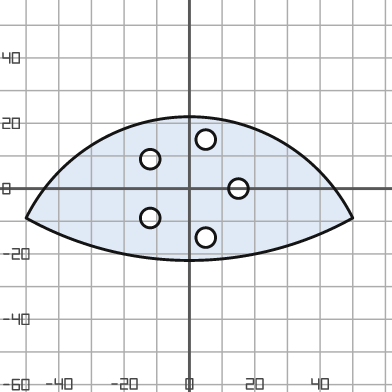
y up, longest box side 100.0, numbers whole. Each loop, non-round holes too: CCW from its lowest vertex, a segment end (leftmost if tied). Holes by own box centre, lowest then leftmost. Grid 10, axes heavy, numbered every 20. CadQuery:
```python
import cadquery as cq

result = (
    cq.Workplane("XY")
    .moveTo(-50.0, -9.0)
    .threePointArc((0.0, -22.0), (50.0, -9.0))
    .threePointArc((0.0, 22.0), (-50.0, -9.0))
    .close()
    .moveTo(5.0, -15.0)
    .circle(3.0)
    .moveTo(-12.0, -9.0)
    .circle(3.0)
    .moveTo(15.0, 0.0)
    .circle(3.0)
    .moveTo(-12.0, 9.0)
    .circle(3.0)
    .moveTo(5.0, 15.0)
    .circle(3.0)
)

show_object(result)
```